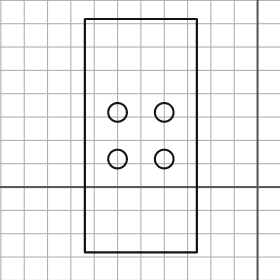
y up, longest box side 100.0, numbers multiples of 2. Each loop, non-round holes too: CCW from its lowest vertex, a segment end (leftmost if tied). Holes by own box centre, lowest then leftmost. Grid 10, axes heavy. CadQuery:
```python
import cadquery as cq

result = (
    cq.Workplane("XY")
    .moveTo(-74.0, -28.0)
    .lineTo(-26.0, -28.0)
    .lineTo(-26.0, 72.0)
    .lineTo(-74.0, 72.0)
    .close()
    .moveTo(-60.0, 12.0)
    .circle(4.0)
    .moveTo(-40.0, 12.0)
    .circle(4.0)
    .moveTo(-60.0, 32.0)
    .circle(4.0)
    .moveTo(-40.0, 32.0)
    .circle(4.0)
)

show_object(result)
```